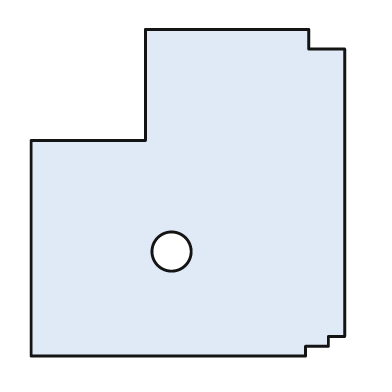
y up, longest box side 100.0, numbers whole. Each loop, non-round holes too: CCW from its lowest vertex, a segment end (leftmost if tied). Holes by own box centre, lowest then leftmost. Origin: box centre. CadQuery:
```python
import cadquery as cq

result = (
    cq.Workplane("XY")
    .moveTo(-48.0, -50.0)
    .lineTo(36.0, -50.0)
    .lineTo(36.0, -47.0)
    .lineTo(43.0, -47.0)
    .lineTo(43.0, -44.0)
    .lineTo(48.0, -44.0)
    .lineTo(48.0, 44.0)
    .lineTo(37.0, 44.0)
    .lineTo(37.0, 50.0)
    .lineTo(-13.0, 50.0)
    .lineTo(-13.0, 16.0)
    .lineTo(-48.0, 16.0)
    .close()
    .moveTo(-5.0, -18.0)
    .circle(6.0)
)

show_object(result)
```